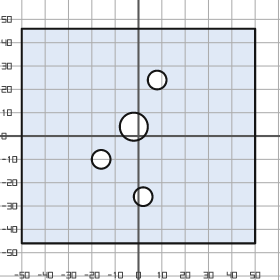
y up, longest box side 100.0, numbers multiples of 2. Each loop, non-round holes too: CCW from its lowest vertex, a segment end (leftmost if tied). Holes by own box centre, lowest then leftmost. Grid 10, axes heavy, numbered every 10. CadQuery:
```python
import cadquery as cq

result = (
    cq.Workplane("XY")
    .moveTo(-50.0, -46.0)
    .lineTo(50.0, -46.0)
    .lineTo(50.0, 46.0)
    .lineTo(-50.0, 46.0)
    .close()
    .moveTo(2.0, -26.0)
    .circle(4.0)
    .moveTo(-16.0, -10.0)
    .circle(4.0)
    .moveTo(-2.0, 4.0)
    .circle(6.0)
    .moveTo(8.0, 24.0)
    .circle(4.0)
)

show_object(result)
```